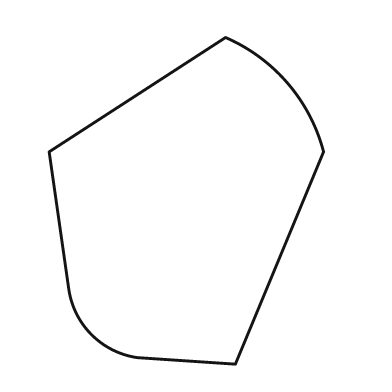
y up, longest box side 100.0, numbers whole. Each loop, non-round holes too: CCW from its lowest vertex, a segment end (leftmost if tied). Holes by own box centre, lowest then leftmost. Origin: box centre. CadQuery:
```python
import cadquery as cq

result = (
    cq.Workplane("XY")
    .moveTo(15.0, -50.0)
    .lineTo(42.0, 15.0)
    .threePointArc((31.0, 36.0), (12.0, 50.0))
    .lineTo(-42.0, 15.0)
    .lineTo(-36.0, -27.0)
    .threePointArc((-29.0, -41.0), (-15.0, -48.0))
    .close()
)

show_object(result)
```